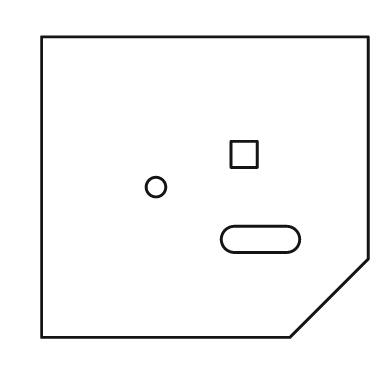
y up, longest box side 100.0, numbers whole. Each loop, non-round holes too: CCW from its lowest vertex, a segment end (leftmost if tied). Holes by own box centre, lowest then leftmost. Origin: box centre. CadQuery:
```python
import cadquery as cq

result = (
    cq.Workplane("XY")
    .moveTo(-50.0, -46.0)
    .lineTo(26.0, -46.0)
    .lineTo(50.0, -22.0)
    .lineTo(50.0, 46.0)
    .lineTo(-50.0, 46.0)
    .close()
    .moveTo(9.0, -20.0)
    .lineTo(25.0, -20.0)
    .threePointArc((29.0, -16.0), (25.0, -12.0))
    .lineTo(9.0, -12.0)
    .threePointArc((5.0, -16.0), (9.0, -20.0))
    .close()
    .moveTo(-15.0, 0.0)
    .circle(3.0)
    .moveTo(8.0, 6.0)
    .lineTo(16.0, 6.0)
    .lineTo(16.0, 14.0)
    .lineTo(8.0, 14.0)
    .close()
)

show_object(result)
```